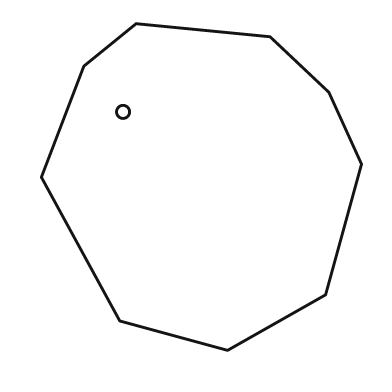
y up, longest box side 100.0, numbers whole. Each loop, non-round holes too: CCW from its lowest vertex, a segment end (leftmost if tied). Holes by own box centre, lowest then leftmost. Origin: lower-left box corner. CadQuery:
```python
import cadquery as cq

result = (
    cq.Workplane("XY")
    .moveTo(57.0, 0.0)
    .lineTo(87.0, 17.0)
    .lineTo(98.0, 57.0)
    .lineTo(88.0, 79.0)
    .lineTo(70.0, 96.0)
    .lineTo(29.0, 100.0)
    .lineTo(13.0, 87.0)
    .lineTo(0.0, 53.0)
    .lineTo(24.0, 9.0)
    .close()
    .moveTo(25.0, 73.0)
    .circle(2.0)
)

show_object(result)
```